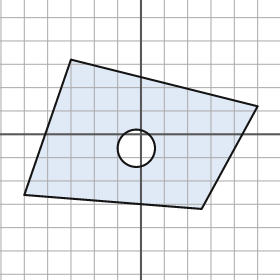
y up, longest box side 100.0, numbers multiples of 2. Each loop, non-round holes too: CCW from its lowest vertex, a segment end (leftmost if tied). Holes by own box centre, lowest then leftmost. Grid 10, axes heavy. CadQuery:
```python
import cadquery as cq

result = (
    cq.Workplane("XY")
    .moveTo(26.0, -32.0)
    .lineTo(50.0, 12.0)
    .lineTo(-30.0, 32.0)
    .lineTo(-50.0, -26.0)
    .close()
    .moveTo(-2.0, -6.0)
    .circle(8.0)
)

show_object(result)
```